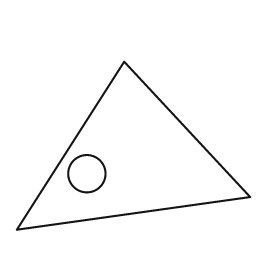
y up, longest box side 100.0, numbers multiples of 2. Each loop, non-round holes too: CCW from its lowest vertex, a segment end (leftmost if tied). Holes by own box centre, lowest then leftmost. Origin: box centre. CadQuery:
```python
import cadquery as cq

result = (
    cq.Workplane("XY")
    .moveTo(-50.0, -36.0)
    .lineTo(50.0, -22.0)
    .lineTo(-4.0, 36.0)
    .close()
    .moveTo(-20.0, -12.0)
    .circle(8.0)
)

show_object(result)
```